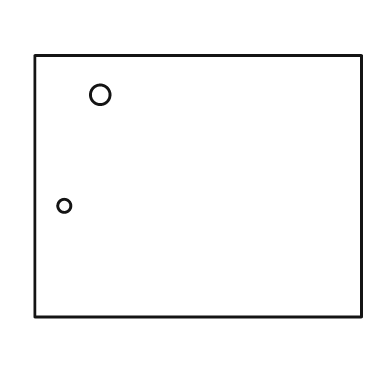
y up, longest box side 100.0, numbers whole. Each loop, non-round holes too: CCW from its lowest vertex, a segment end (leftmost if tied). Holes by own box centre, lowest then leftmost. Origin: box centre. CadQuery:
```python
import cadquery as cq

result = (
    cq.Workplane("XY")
    .moveTo(-50.0, -40.0)
    .lineTo(50.0, -40.0)
    .lineTo(50.0, 40.0)
    .lineTo(-50.0, 40.0)
    .close()
    .moveTo(-41.0, -6.0)
    .circle(2.0)
    .moveTo(-30.0, 28.0)
    .circle(3.0)
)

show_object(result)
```